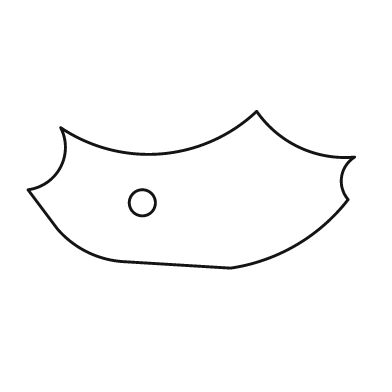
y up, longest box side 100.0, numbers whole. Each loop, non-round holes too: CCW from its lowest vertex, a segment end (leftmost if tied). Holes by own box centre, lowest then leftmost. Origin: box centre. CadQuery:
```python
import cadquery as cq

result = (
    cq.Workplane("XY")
    .moveTo(12.0, -24.0)
    .threePointArc((32.0, -17.0), (48.0, -3.0))
    .threePointArc((46.0, 4.0), (50.0, 10.0))
    .threePointArc((33.0, 13.0), (20.0, 24.0))
    .threePointArc((-9.0, 11.0), (-40.0, 19.0))
    .threePointArc((-40.0, 7.0), (-50.0, 0.0))
    .lineTo(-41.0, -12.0)
    .threePointArc((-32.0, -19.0), (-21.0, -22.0))
    .close()
    .moveTo(-15.0, -4.0)
    .circle(4.0)
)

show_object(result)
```